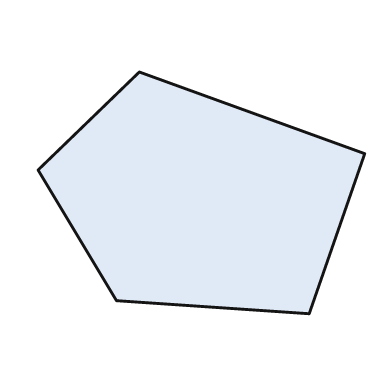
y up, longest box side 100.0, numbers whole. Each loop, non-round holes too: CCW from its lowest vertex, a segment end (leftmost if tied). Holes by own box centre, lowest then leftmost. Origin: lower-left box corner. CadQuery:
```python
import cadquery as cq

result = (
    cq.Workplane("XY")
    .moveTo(83.0, 0.0)
    .lineTo(100.0, 49.0)
    .lineTo(31.0, 74.0)
    .lineTo(0.0, 44.0)
    .lineTo(24.0, 4.0)
    .close()
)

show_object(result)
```